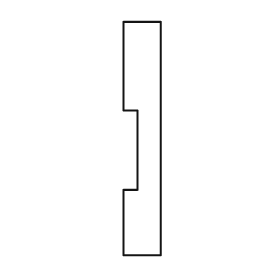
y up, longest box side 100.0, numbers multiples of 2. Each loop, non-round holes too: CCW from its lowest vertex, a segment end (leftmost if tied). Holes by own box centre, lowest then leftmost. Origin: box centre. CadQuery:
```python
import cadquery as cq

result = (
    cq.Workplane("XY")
    .moveTo(-8.0, -50.0)
    .lineTo(8.0, -50.0)
    .lineTo(8.0, 50.0)
    .lineTo(-8.0, 50.0)
    .lineTo(-8.0, 12.0)
    .lineTo(-2.0, 12.0)
    .lineTo(-2.0, -22.0)
    .lineTo(-8.0, -22.0)
    .close()
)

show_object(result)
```